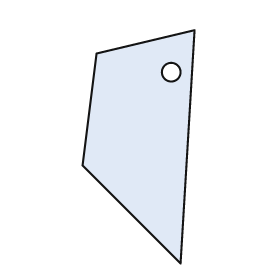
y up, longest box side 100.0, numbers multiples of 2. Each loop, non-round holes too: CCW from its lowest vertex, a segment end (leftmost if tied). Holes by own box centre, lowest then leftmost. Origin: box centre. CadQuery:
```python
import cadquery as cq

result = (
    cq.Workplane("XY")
    .moveTo(18.0, -50.0)
    .lineTo(24.0, 50.0)
    .lineTo(-18.0, 40.0)
    .lineTo(-24.0, -8.0)
    .close()
    .moveTo(14.0, 32.0)
    .circle(4.0)
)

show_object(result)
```